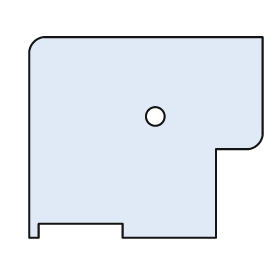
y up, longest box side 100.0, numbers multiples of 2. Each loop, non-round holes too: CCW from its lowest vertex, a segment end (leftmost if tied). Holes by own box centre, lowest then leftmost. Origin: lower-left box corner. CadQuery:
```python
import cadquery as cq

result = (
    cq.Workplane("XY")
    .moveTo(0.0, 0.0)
    .lineTo(4.0, 0.0)
    .lineTo(4.0, 6.0)
    .lineTo(40.0, 6.0)
    .lineTo(40.0, 0.0)
    .lineTo(80.0, 0.0)
    .lineTo(80.0, 38.0)
    .lineTo(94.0, 38.0)
    .threePointArc((98.0, 40.0), (100.0, 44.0))
    .lineTo(100.0, 86.0)
    .lineTo(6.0, 86.0)
    .threePointArc((2.0, 84.0), (0.0, 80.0))
    .close()
    .moveTo(54.0, 52.0)
    .circle(4.0)
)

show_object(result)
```